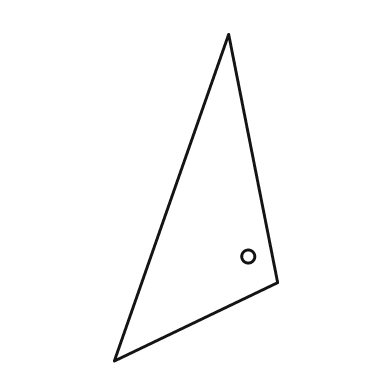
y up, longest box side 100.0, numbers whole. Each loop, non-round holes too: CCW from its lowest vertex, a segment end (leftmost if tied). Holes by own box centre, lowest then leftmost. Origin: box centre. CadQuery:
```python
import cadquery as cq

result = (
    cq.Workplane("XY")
    .moveTo(-25.0, -50.0)
    .lineTo(25.0, -26.0)
    .lineTo(10.0, 50.0)
    .close()
    .moveTo(16.0, -18.0)
    .circle(2.0)
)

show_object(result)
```